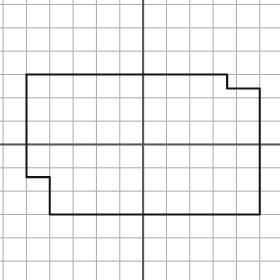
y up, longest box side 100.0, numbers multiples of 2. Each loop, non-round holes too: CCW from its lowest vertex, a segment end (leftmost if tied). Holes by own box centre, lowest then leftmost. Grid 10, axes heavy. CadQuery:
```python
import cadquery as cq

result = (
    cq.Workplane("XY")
    .moveTo(-40.0, -30.0)
    .lineTo(50.0, -30.0)
    .lineTo(50.0, 24.0)
    .lineTo(36.0, 24.0)
    .lineTo(36.0, 30.0)
    .lineTo(-50.0, 30.0)
    .lineTo(-50.0, -14.0)
    .lineTo(-40.0, -14.0)
    .close()
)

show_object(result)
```